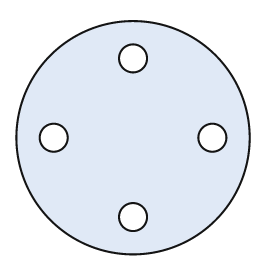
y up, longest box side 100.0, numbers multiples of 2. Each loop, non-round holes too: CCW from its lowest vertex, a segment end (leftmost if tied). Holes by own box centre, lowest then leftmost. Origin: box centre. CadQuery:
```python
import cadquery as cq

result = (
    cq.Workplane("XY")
    .moveTo(0.0, 0.0)
    .circle(50.0)
    .moveTo(0.0, -34.0)
    .circle(6.0)
    .moveTo(-34.0, 0.0)
    .circle(6.0)
    .moveTo(34.0, 0.0)
    .circle(6.0)
    .moveTo(0.0, 34.0)
    .circle(6.0)
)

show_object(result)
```